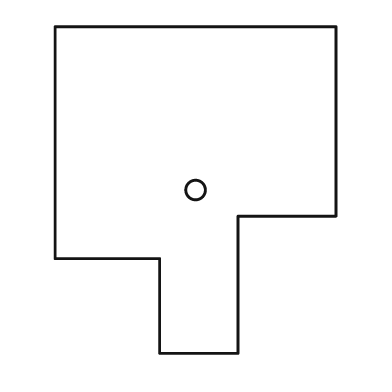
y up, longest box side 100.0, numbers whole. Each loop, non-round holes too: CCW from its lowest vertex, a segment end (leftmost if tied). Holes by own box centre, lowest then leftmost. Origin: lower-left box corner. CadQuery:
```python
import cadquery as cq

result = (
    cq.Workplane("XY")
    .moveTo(32.0, 0.0)
    .lineTo(56.0, 0.0)
    .lineTo(56.0, 42.0)
    .lineTo(86.0, 42.0)
    .lineTo(86.0, 100.0)
    .lineTo(0.0, 100.0)
    .lineTo(0.0, 29.0)
    .lineTo(32.0, 29.0)
    .close()
    .moveTo(43.0, 50.0)
    .circle(3.0)
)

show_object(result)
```